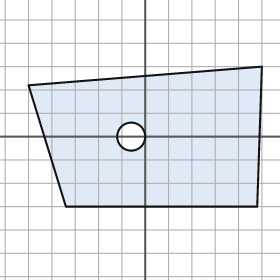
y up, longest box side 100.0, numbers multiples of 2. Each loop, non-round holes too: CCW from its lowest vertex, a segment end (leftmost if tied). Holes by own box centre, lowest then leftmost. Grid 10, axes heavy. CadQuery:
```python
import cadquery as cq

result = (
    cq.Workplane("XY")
    .moveTo(-34.0, -30.0)
    .lineTo(48.0, -30.0)
    .lineTo(50.0, 30.0)
    .lineTo(-50.0, 22.0)
    .close()
    .moveTo(-6.0, 0.0)
    .circle(6.0)
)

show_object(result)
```